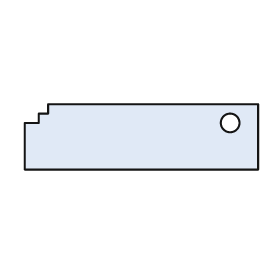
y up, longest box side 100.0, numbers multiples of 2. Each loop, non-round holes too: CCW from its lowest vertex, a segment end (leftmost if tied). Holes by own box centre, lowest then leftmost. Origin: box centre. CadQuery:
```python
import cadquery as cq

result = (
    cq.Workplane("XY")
    .moveTo(-50.0, -14.0)
    .lineTo(50.0, -14.0)
    .lineTo(50.0, 14.0)
    .lineTo(-40.0, 14.0)
    .lineTo(-40.0, 10.0)
    .lineTo(-44.0, 10.0)
    .lineTo(-44.0, 6.0)
    .lineTo(-50.0, 6.0)
    .close()
    .moveTo(38.0, 6.0)
    .circle(4.0)
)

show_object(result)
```